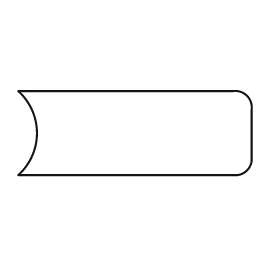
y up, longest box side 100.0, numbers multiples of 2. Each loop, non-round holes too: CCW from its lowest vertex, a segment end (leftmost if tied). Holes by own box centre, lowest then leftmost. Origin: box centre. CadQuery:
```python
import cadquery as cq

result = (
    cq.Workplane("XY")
    .moveTo(-50.0, -18.0)
    .lineTo(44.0, -18.0)
    .threePointArc((48.0, -16.0), (50.0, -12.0))
    .lineTo(50.0, 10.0)
    .threePointArc((48.0, 16.0), (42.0, 18.0))
    .lineTo(-50.0, 18.0)
    .threePointArc((-42.0, 0.0), (-50.0, -18.0))
    .close()
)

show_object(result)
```